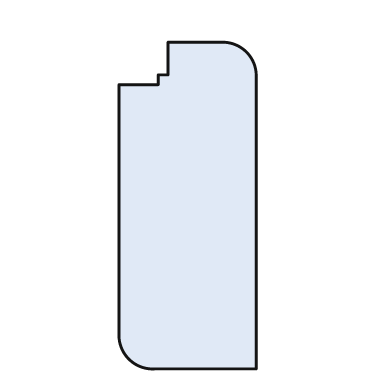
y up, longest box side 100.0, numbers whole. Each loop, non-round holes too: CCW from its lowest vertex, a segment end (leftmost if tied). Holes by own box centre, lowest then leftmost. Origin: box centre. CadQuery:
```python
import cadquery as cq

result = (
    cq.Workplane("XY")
    .moveTo(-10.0, -50.0)
    .lineTo(21.0, -50.0)
    .lineTo(21.0, 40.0)
    .threePointArc((18.0, 47.0), (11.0, 50.0))
    .lineTo(-6.0, 50.0)
    .lineTo(-6.0, 40.0)
    .lineTo(-9.0, 40.0)
    .lineTo(-9.0, 37.0)
    .lineTo(-21.0, 37.0)
    .lineTo(-21.0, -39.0)
    .threePointArc((-18.0, -47.0), (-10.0, -50.0))
    .close()
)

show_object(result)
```